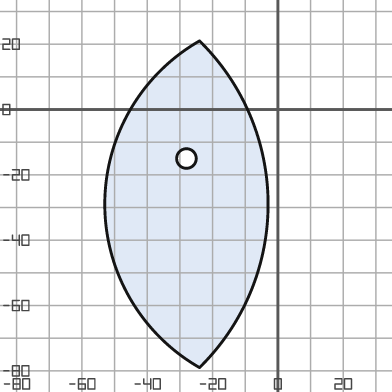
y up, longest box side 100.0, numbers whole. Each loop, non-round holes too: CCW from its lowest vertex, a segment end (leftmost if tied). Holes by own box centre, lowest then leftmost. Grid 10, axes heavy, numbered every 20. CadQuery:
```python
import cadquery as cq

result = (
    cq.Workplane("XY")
    .moveTo(-24.0, -79.0)
    .threePointArc((-3.0, -29.0), (-24.0, 21.0))
    .threePointArc((-53.0, -29.0), (-24.0, -79.0))
    .close()
    .moveTo(-28.0, -15.0)
    .circle(3.0)
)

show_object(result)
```